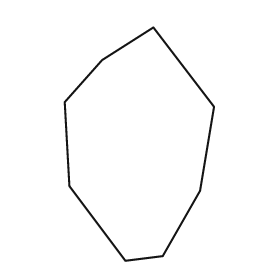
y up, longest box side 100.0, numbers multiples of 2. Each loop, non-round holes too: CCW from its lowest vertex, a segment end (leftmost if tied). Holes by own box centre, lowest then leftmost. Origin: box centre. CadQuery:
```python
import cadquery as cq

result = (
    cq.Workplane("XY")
    .moveTo(-6.0, -50.0)
    .lineTo(10.0, -48.0)
    .lineTo(26.0, -20.0)
    .lineTo(32.0, 16.0)
    .lineTo(6.0, 50.0)
    .lineTo(-16.0, 36.0)
    .lineTo(-32.0, 18.0)
    .lineTo(-30.0, -18.0)
    .close()
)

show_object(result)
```